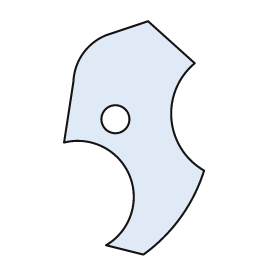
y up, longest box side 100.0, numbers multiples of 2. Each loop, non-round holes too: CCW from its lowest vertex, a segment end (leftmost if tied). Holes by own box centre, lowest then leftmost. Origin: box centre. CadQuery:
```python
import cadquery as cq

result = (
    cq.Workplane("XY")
    .moveTo(4.0, -50.0)
    .threePointArc((20.0, -34.0), (30.0, -14.0))
    .threePointArc((16.0, 8.0), (26.0, 32.0))
    .lineTo(6.0, 50.0)
    .lineTo(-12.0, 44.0)
    .threePointArc((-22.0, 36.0), (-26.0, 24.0))
    .lineTo(-30.0, -2.0)
    .threePointArc((-2.0, -16.0), (-12.0, -46.0))
    .close()
    .moveTo(-8.0, 8.0)
    .circle(6.0)
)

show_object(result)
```